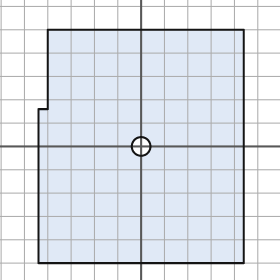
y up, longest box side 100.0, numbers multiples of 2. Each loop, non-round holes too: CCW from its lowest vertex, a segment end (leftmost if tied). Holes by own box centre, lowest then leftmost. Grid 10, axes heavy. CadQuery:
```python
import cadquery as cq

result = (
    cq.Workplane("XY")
    .moveTo(-44.0, -50.0)
    .lineTo(44.0, -50.0)
    .lineTo(44.0, 50.0)
    .lineTo(-40.0, 50.0)
    .lineTo(-40.0, 16.0)
    .lineTo(-44.0, 16.0)
    .close()
    .moveTo(0.0, 0.0)
    .circle(4.0)
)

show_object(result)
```